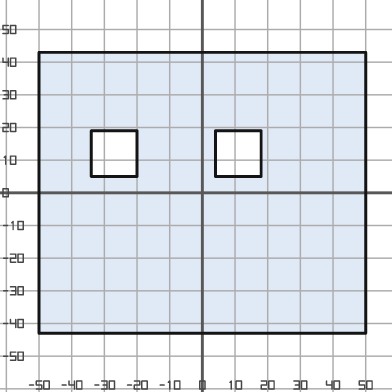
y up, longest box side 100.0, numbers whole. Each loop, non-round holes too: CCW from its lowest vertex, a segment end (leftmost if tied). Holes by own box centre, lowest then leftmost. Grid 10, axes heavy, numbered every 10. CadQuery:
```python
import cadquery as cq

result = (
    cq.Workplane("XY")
    .moveTo(-50.0, -43.0)
    .lineTo(50.0, -43.0)
    .lineTo(50.0, 43.0)
    .lineTo(-50.0, 43.0)
    .close()
    .moveTo(-34.0, 5.0)
    .lineTo(-20.0, 5.0)
    .lineTo(-20.0, 19.0)
    .lineTo(-34.0, 19.0)
    .close()
    .moveTo(4.0, 5.0)
    .lineTo(18.0, 5.0)
    .lineTo(18.0, 19.0)
    .lineTo(4.0, 19.0)
    .close()
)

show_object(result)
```